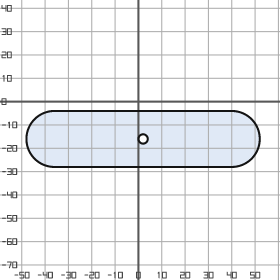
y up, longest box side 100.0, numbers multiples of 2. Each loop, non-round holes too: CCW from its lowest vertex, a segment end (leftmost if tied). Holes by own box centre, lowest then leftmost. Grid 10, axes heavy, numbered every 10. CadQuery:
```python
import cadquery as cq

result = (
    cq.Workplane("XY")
    .moveTo(-36.0, -28.0)
    .lineTo(40.0, -28.0)
    .threePointArc((52.0, -16.0), (40.0, -4.0))
    .lineTo(-36.0, -4.0)
    .threePointArc((-48.0, -16.0), (-36.0, -28.0))
    .close()
    .moveTo(2.0, -16.0)
    .circle(2.0)
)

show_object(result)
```